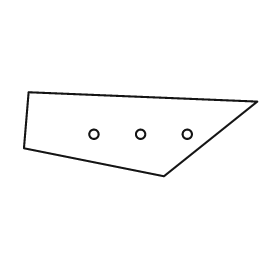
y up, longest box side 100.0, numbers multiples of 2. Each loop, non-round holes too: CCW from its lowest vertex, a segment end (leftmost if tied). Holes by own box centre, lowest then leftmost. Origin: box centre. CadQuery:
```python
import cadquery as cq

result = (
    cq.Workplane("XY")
    .moveTo(10.0, -18.0)
    .lineTo(50.0, 14.0)
    .lineTo(-48.0, 18.0)
    .lineTo(-50.0, -6.0)
    .close()
    .moveTo(-20.0, 0.0)
    .circle(2.0)
    .moveTo(0.0, 0.0)
    .circle(2.0)
    .moveTo(20.0, 0.0)
    .circle(2.0)
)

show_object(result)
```